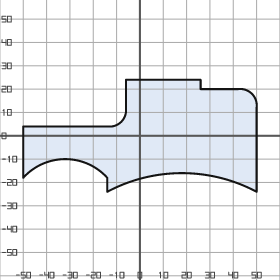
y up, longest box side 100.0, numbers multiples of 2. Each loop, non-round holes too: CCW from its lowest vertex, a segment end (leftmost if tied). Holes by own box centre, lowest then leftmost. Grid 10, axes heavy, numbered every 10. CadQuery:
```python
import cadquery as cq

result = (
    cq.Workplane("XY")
    .moveTo(-14.0, -24.0)
    .threePointArc((18.0, -16.0), (50.0, -24.0))
    .lineTo(50.0, 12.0)
    .threePointArc((48.0, 18.0), (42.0, 20.0))
    .lineTo(26.0, 20.0)
    .lineTo(26.0, 24.0)
    .lineTo(-6.0, 24.0)
    .lineTo(-6.0, 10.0)
    .threePointArc((-8.0, 6.0), (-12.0, 4.0))
    .lineTo(-50.0, 4.0)
    .lineTo(-50.0, -18.0)
    .threePointArc((-32.0, -10.0), (-14.0, -18.0))
    .close()
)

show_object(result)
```